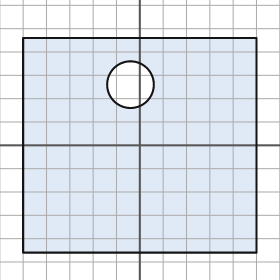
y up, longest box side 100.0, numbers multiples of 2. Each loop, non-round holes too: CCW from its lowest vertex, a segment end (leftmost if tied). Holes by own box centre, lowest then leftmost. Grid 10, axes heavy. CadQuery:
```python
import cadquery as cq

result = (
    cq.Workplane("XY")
    .moveTo(-50.0, -46.0)
    .lineTo(50.0, -46.0)
    .lineTo(50.0, 46.0)
    .lineTo(-50.0, 46.0)
    .close()
    .moveTo(-4.0, 26.0)
    .circle(10.0)
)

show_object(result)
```